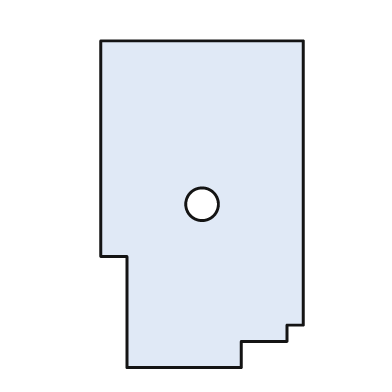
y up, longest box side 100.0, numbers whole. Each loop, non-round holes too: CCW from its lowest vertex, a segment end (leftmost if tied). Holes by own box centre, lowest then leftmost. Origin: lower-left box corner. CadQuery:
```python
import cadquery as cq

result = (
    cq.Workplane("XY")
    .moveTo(8.0, 0.0)
    .lineTo(43.0, 0.0)
    .lineTo(43.0, 8.0)
    .lineTo(57.0, 8.0)
    .lineTo(57.0, 13.0)
    .lineTo(62.0, 13.0)
    .lineTo(62.0, 100.0)
    .lineTo(0.0, 100.0)
    .lineTo(0.0, 34.0)
    .lineTo(8.0, 34.0)
    .close()
    .moveTo(31.0, 50.0)
    .circle(5.0)
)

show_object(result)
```